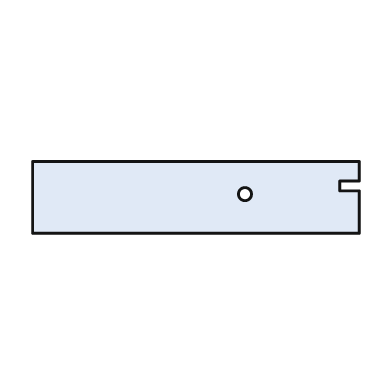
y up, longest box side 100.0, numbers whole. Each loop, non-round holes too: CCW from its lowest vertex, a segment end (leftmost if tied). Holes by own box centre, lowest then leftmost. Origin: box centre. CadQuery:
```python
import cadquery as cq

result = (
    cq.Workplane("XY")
    .moveTo(-50.0, -11.0)
    .lineTo(50.0, -11.0)
    .lineTo(50.0, 2.0)
    .lineTo(44.0, 2.0)
    .lineTo(44.0, 5.0)
    .lineTo(50.0, 5.0)
    .lineTo(50.0, 11.0)
    .lineTo(-50.0, 11.0)
    .close()
    .moveTo(15.0, 1.0)
    .circle(2.0)
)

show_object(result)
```